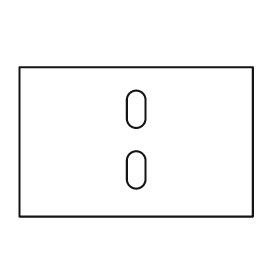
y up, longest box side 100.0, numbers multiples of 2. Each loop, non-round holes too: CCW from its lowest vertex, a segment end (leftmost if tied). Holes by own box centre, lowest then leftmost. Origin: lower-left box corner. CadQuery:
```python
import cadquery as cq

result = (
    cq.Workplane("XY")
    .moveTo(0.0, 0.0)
    .lineTo(100.0, 0.0)
    .lineTo(100.0, 64.0)
    .lineTo(0.0, 64.0)
    .close()
    .moveTo(46.0, 16.0)
    .threePointArc((50.0, 12.0), (54.0, 16.0))
    .lineTo(54.0, 24.0)
    .threePointArc((50.0, 28.0), (46.0, 24.0))
    .close()
    .moveTo(46.0, 42.0)
    .threePointArc((50.0, 38.0), (54.0, 42.0))
    .lineTo(54.0, 50.0)
    .threePointArc((50.0, 54.0), (46.0, 50.0))
    .close()
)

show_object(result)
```